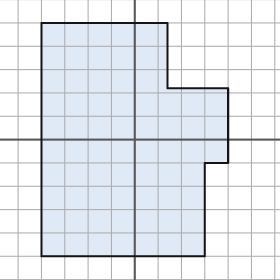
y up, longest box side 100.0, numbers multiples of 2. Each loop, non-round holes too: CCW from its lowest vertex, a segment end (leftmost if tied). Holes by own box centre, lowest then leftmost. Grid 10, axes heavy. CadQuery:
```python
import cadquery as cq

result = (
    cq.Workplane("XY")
    .moveTo(-40.0, -50.0)
    .lineTo(30.0, -50.0)
    .lineTo(30.0, -10.0)
    .lineTo(40.0, -10.0)
    .lineTo(40.0, 22.0)
    .lineTo(14.0, 22.0)
    .lineTo(14.0, 50.0)
    .lineTo(-40.0, 50.0)
    .close()
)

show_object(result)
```